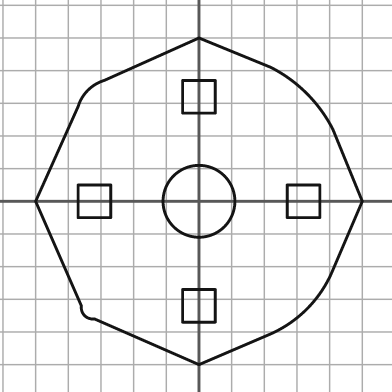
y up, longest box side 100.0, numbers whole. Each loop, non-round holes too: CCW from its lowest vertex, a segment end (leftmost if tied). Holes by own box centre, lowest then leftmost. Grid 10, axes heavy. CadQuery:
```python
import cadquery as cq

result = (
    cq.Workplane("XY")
    .moveTo(0.0, -50.0)
    .lineTo(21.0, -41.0)
    .threePointArc((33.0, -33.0), (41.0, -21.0))
    .lineTo(50.0, 0.0)
    .lineTo(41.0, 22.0)
    .threePointArc((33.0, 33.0), (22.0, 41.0))
    .lineTo(0.0, 50.0)
    .lineTo(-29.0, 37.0)
    .threePointArc((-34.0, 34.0), (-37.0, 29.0))
    .lineTo(-50.0, 0.0)
    .lineTo(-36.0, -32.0)
    .threePointArc((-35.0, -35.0), (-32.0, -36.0))
    .close()
    .moveTo(-5.0, -37.0)
    .lineTo(5.0, -37.0)
    .lineTo(5.0, -27.0)
    .lineTo(-5.0, -27.0)
    .close()
    .moveTo(-37.0, -5.0)
    .lineTo(-27.0, -5.0)
    .lineTo(-27.0, 5.0)
    .lineTo(-37.0, 5.0)
    .close()
    .moveTo(0.0, 0.0)
    .circle(11.0)
    .moveTo(27.0, -5.0)
    .lineTo(37.0, -5.0)
    .lineTo(37.0, 5.0)
    .lineTo(27.0, 5.0)
    .close()
    .moveTo(-5.0, 27.0)
    .lineTo(5.0, 27.0)
    .lineTo(5.0, 37.0)
    .lineTo(-5.0, 37.0)
    .close()
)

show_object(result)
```